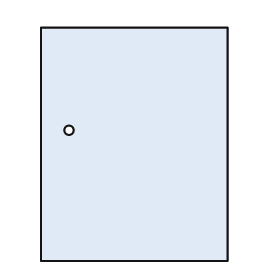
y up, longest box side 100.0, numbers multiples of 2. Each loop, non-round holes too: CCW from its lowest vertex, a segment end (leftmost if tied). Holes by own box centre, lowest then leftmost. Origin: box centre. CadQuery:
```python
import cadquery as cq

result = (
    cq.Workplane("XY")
    .moveTo(-40.0, -50.0)
    .lineTo(40.0, -50.0)
    .lineTo(40.0, 50.0)
    .lineTo(-40.0, 50.0)
    .close()
    .moveTo(-28.0, 6.0)
    .circle(2.0)
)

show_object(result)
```